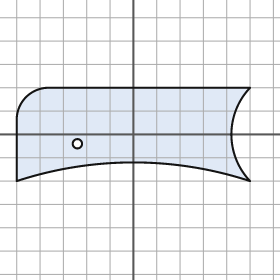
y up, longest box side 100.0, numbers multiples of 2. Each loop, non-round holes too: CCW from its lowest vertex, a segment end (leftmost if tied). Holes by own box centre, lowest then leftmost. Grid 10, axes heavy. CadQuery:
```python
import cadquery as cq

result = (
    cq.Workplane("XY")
    .moveTo(-50.0, -20.0)
    .threePointArc((0.0, -12.0), (50.0, -20.0))
    .threePointArc((42.0, 0.0), (50.0, 20.0))
    .lineTo(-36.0, 20.0)
    .threePointArc((-46.0, 16.0), (-50.0, 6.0))
    .close()
    .moveTo(-24.0, -4.0)
    .circle(2.0)
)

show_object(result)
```